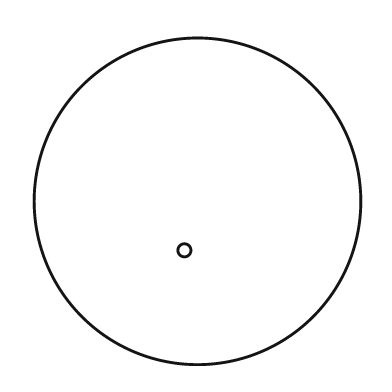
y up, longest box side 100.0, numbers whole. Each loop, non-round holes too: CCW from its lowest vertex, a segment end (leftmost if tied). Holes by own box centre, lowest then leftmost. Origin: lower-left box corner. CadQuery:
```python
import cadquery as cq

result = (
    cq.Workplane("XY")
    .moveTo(50.0, 50.0)
    .circle(50.0)
    .moveTo(46.0, 35.0)
    .circle(2.0)
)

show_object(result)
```